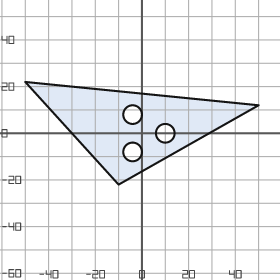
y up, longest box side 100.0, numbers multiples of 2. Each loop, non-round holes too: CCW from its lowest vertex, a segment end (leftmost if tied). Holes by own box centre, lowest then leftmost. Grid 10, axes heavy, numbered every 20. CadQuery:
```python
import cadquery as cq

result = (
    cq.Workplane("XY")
    .moveTo(-10.0, -22.0)
    .lineTo(50.0, 12.0)
    .lineTo(-50.0, 22.0)
    .close()
    .moveTo(-4.0, -8.0)
    .circle(4.0)
    .moveTo(10.0, 0.0)
    .circle(4.0)
    .moveTo(-4.0, 8.0)
    .circle(4.0)
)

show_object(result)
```